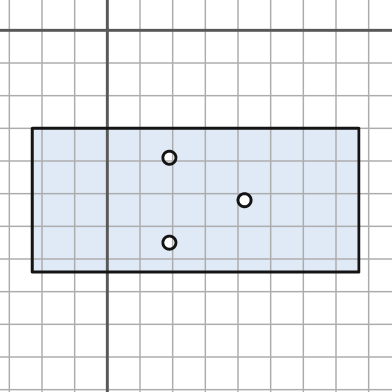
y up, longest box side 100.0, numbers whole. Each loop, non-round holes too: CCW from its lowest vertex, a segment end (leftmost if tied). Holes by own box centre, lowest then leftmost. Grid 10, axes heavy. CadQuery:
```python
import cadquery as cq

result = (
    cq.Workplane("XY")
    .moveTo(-23.0, -74.0)
    .lineTo(77.0, -74.0)
    .lineTo(77.0, -30.0)
    .lineTo(-23.0, -30.0)
    .close()
    .moveTo(19.0, -65.0)
    .circle(2.0)
    .moveTo(42.0, -52.0)
    .circle(2.0)
    .moveTo(19.0, -39.0)
    .circle(2.0)
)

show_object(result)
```